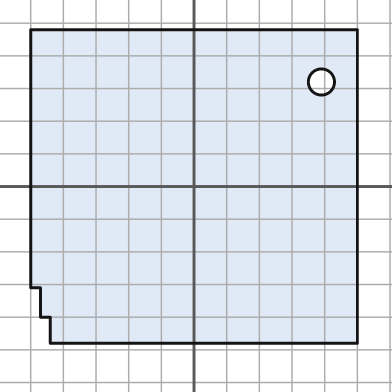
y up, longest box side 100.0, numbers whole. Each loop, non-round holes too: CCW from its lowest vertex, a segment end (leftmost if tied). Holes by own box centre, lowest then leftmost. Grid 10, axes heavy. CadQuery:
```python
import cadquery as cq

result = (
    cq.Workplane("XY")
    .moveTo(-44.0, -48.0)
    .lineTo(50.0, -48.0)
    .lineTo(50.0, 48.0)
    .lineTo(-50.0, 48.0)
    .lineTo(-50.0, -31.0)
    .lineTo(-47.0, -31.0)
    .lineTo(-47.0, -40.0)
    .lineTo(-44.0, -40.0)
    .close()
    .moveTo(39.0, 32.0)
    .circle(4.0)
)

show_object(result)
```